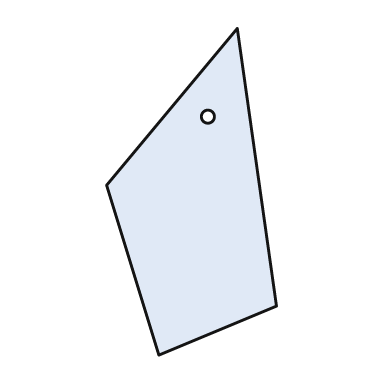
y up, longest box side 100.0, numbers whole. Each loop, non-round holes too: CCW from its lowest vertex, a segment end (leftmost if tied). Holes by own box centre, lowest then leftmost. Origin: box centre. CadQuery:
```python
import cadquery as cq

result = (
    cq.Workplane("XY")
    .moveTo(-10.0, -50.0)
    .lineTo(26.0, -35.0)
    .lineTo(14.0, 50.0)
    .lineTo(-26.0, 2.0)
    .close()
    .moveTo(5.0, 23.0)
    .circle(2.0)
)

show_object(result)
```